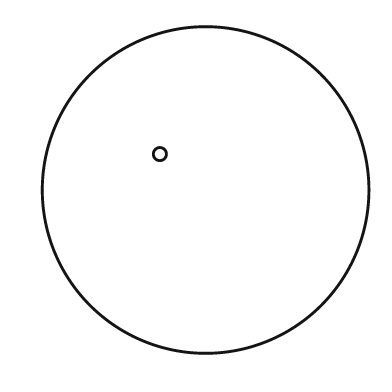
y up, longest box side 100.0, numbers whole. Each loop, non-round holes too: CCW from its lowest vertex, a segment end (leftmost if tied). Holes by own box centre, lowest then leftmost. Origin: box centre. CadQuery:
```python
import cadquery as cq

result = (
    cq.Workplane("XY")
    .moveTo(0.0, 0.0)
    .circle(50.0)
    .moveTo(-14.0, 11.0)
    .circle(2.0)
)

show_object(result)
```